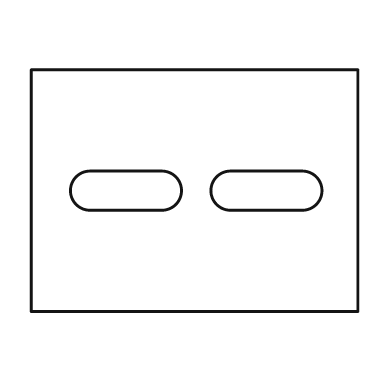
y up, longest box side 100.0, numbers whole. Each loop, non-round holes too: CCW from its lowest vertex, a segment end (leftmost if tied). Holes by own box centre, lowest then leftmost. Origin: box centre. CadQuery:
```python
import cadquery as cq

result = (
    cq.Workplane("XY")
    .moveTo(-50.0, -37.0)
    .lineTo(50.0, -37.0)
    .lineTo(50.0, 37.0)
    .lineTo(-50.0, 37.0)
    .close()
    .moveTo(-32.0, -6.0)
    .lineTo(-10.0, -6.0)
    .threePointArc((-4.0, 0.0), (-10.0, 6.0))
    .lineTo(-32.0, 6.0)
    .threePointArc((-38.0, 0.0), (-32.0, -6.0))
    .close()
    .moveTo(11.0, -6.0)
    .lineTo(33.0, -6.0)
    .threePointArc((39.0, 0.0), (33.0, 6.0))
    .lineTo(11.0, 6.0)
    .threePointArc((5.0, 0.0), (11.0, -6.0))
    .close()
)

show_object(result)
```